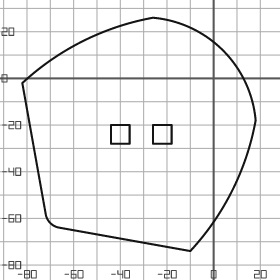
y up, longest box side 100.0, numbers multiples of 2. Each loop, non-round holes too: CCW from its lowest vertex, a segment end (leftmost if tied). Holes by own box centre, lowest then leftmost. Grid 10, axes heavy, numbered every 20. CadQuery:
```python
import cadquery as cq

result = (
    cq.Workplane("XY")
    .moveTo(-10.0, -74.0)
    .threePointArc((8.0, -48.0), (18.0, -18.0))
    .threePointArc((4.0, 12.0), (-26.0, 26.0))
    .threePointArc((-56.0, 16.0), (-82.0, -2.0))
    .lineTo(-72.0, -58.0)
    .threePointArc((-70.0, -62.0), (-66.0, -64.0))
    .close()
    .moveTo(-44.0, -28.0)
    .lineTo(-36.0, -28.0)
    .lineTo(-36.0, -20.0)
    .lineTo(-44.0, -20.0)
    .close()
    .moveTo(-26.0, -28.0)
    .lineTo(-18.0, -28.0)
    .lineTo(-18.0, -20.0)
    .lineTo(-26.0, -20.0)
    .close()
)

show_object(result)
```